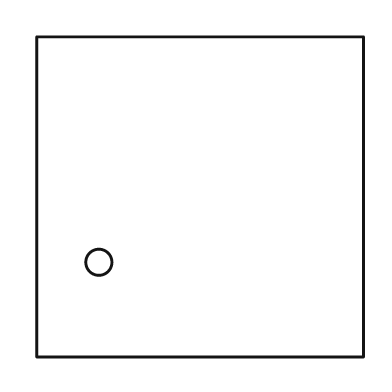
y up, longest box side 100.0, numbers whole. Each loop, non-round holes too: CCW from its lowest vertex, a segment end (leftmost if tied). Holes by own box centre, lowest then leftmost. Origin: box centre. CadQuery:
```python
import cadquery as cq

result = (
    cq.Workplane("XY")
    .moveTo(-50.0, -49.0)
    .lineTo(50.0, -49.0)
    .lineTo(50.0, 49.0)
    .lineTo(-50.0, 49.0)
    .close()
    .moveTo(-31.0, -20.0)
    .circle(4.0)
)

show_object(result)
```